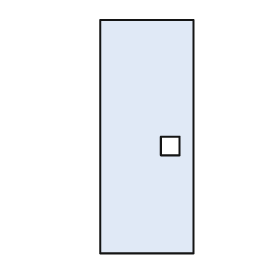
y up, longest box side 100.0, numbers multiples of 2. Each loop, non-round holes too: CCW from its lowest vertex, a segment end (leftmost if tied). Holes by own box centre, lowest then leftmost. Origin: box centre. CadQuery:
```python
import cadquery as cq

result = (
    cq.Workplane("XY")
    .moveTo(-20.0, -50.0)
    .lineTo(20.0, -50.0)
    .lineTo(20.0, 50.0)
    .lineTo(-20.0, 50.0)
    .close()
    .moveTo(6.0, -8.0)
    .lineTo(14.0, -8.0)
    .lineTo(14.0, 0.0)
    .lineTo(6.0, 0.0)
    .close()
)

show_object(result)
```